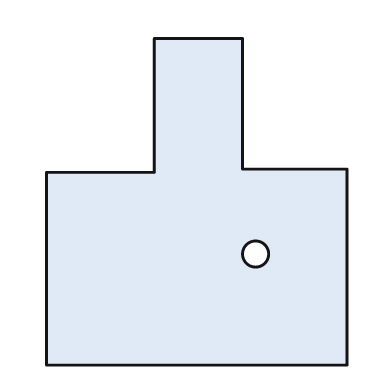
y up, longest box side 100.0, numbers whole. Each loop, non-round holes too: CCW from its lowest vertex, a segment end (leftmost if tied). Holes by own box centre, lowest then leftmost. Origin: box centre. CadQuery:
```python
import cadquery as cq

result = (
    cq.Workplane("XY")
    .moveTo(-46.0, -50.0)
    .lineTo(46.0, -50.0)
    .lineTo(46.0, 10.0)
    .lineTo(14.0, 10.0)
    .lineTo(14.0, 50.0)
    .lineTo(-13.0, 50.0)
    .lineTo(-13.0, 9.0)
    .lineTo(-46.0, 9.0)
    .close()
    .moveTo(18.0, -16.0)
    .circle(4.0)
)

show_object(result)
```